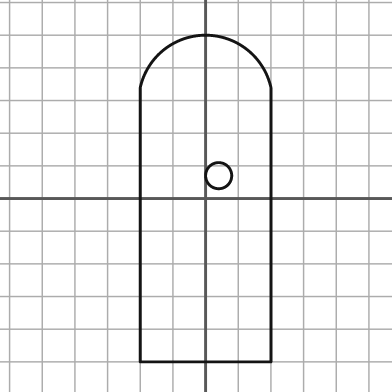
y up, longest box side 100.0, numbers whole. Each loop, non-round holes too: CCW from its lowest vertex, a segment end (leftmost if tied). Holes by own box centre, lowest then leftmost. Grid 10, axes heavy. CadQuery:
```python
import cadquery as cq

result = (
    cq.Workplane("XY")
    .moveTo(-20.0, -50.0)
    .lineTo(20.0, -50.0)
    .lineTo(20.0, 34.0)
    .threePointArc((0.0, 50.0), (-20.0, 34.0))
    .close()
    .moveTo(4.0, 7.0)
    .circle(4.0)
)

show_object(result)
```